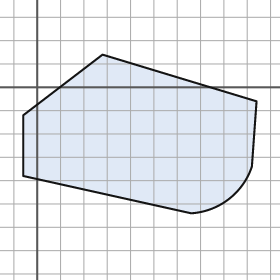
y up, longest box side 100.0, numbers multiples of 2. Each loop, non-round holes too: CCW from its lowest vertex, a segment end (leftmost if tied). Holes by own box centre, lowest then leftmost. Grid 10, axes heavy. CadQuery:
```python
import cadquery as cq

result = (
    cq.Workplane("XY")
    .moveTo(66.0, -54.0)
    .threePointArc((82.0, -48.0), (92.0, -34.0))
    .lineTo(94.0, -6.0)
    .lineTo(28.0, 14.0)
    .lineTo(-6.0, -12.0)
    .lineTo(-6.0, -38.0)
    .close()
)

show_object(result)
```